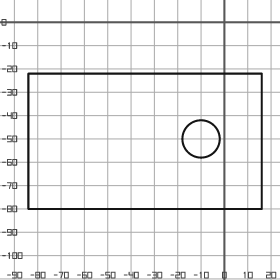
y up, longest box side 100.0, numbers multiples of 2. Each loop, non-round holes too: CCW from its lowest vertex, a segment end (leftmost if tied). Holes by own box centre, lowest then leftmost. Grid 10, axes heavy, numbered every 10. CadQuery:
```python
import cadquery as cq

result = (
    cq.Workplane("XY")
    .moveTo(-84.0, -80.0)
    .lineTo(16.0, -80.0)
    .lineTo(16.0, -22.0)
    .lineTo(-84.0, -22.0)
    .close()
    .moveTo(-10.0, -50.0)
    .circle(8.0)
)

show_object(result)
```